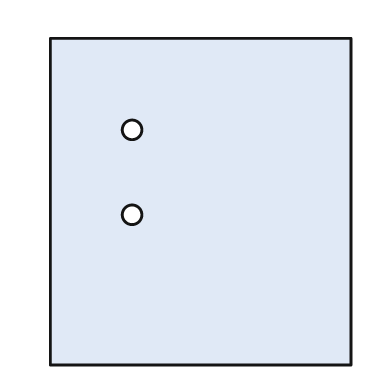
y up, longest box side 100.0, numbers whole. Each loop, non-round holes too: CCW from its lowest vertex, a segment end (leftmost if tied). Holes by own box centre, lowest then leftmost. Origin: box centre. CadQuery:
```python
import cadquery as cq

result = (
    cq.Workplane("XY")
    .moveTo(-46.0, -50.0)
    .lineTo(46.0, -50.0)
    .lineTo(46.0, 50.0)
    .lineTo(-46.0, 50.0)
    .close()
    .moveTo(-21.0, -4.0)
    .circle(3.0)
    .moveTo(-21.0, 22.0)
    .circle(3.0)
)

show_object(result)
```